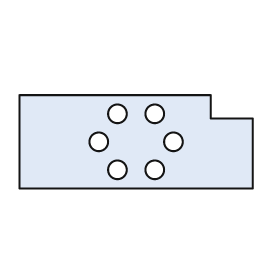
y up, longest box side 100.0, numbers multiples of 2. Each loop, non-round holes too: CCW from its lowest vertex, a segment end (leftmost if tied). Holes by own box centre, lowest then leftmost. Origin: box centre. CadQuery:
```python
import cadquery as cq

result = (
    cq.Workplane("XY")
    .moveTo(-50.0, -20.0)
    .lineTo(50.0, -20.0)
    .lineTo(50.0, 10.0)
    .lineTo(32.0, 10.0)
    .lineTo(32.0, 20.0)
    .lineTo(-50.0, 20.0)
    .close()
    .moveTo(-8.0, -12.0)
    .circle(4.0)
    .moveTo(8.0, -12.0)
    .circle(4.0)
    .moveTo(-16.0, 0.0)
    .circle(4.0)
    .moveTo(16.0, 0.0)
    .circle(4.0)
    .moveTo(-8.0, 12.0)
    .circle(4.0)
    .moveTo(8.0, 12.0)
    .circle(4.0)
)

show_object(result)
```